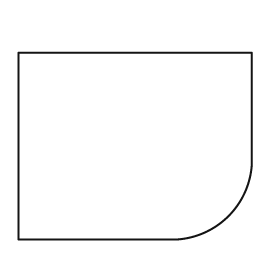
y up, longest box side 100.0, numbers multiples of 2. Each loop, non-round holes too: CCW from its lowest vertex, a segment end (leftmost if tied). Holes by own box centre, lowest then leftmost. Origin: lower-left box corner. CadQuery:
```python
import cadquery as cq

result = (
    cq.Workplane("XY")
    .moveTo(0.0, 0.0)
    .lineTo(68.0, 0.0)
    .threePointArc((90.0, 10.0), (100.0, 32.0))
    .lineTo(100.0, 80.0)
    .lineTo(0.0, 80.0)
    .close()
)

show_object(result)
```